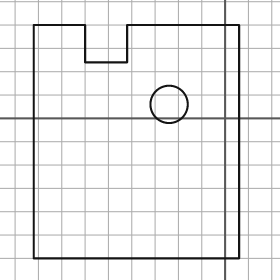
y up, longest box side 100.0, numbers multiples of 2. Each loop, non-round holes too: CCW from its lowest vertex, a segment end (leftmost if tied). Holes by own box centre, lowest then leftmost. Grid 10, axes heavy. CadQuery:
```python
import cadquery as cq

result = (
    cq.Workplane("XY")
    .moveTo(-82.0, -60.0)
    .lineTo(6.0, -60.0)
    .lineTo(6.0, 40.0)
    .lineTo(-42.0, 40.0)
    .lineTo(-42.0, 24.0)
    .lineTo(-60.0, 24.0)
    .lineTo(-60.0, 40.0)
    .lineTo(-82.0, 40.0)
    .close()
    .moveTo(-24.0, 6.0)
    .circle(8.0)
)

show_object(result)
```